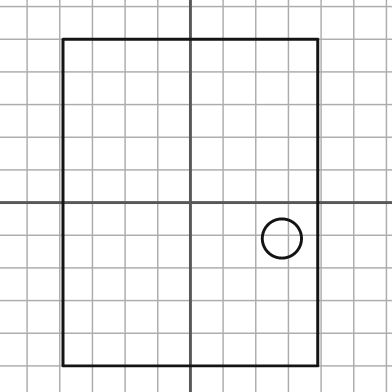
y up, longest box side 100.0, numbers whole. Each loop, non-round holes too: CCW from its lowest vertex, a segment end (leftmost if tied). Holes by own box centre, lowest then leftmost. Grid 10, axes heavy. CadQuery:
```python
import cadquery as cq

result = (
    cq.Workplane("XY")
    .moveTo(-39.0, -50.0)
    .lineTo(39.0, -50.0)
    .lineTo(39.0, 50.0)
    .lineTo(-39.0, 50.0)
    .close()
    .moveTo(28.0, -11.0)
    .circle(6.0)
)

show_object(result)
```